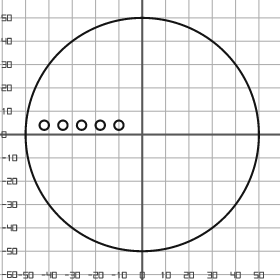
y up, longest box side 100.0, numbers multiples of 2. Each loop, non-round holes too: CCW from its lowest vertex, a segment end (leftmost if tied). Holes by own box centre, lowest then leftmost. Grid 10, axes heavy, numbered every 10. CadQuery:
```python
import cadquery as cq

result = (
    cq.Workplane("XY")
    .moveTo(0.0, 0.0)
    .circle(50.0)
    .moveTo(-42.0, 4.0)
    .circle(2.0)
    .moveTo(-34.0, 4.0)
    .circle(2.0)
    .moveTo(-26.0, 4.0)
    .circle(2.0)
    .moveTo(-18.0, 4.0)
    .circle(2.0)
    .moveTo(-10.0, 4.0)
    .circle(2.0)
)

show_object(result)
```